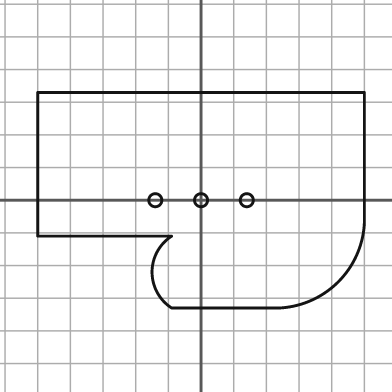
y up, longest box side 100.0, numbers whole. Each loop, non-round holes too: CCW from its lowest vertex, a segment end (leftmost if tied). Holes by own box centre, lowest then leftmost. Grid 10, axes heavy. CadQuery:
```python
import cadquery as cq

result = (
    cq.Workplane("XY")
    .moveTo(-9.0, -33.0)
    .lineTo(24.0, -33.0)
    .threePointArc((42.0, -25.0), (50.0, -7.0))
    .lineTo(50.0, 33.0)
    .lineTo(-50.0, 33.0)
    .lineTo(-50.0, -11.0)
    .lineTo(-9.0, -11.0)
    .threePointArc((-15.0, -22.0), (-9.0, -33.0))
    .close()
    .moveTo(-14.0, 0.0)
    .circle(2.0)
    .moveTo(0.0, 0.0)
    .circle(2.0)
    .moveTo(14.0, 0.0)
    .circle(2.0)
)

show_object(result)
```